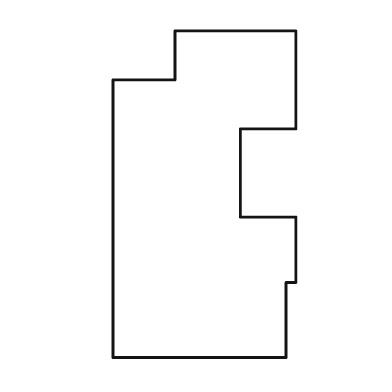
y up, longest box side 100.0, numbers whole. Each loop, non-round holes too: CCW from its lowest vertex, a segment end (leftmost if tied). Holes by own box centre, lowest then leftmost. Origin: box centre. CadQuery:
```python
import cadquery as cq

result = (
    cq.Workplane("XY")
    .moveTo(-28.0, -50.0)
    .lineTo(25.0, -50.0)
    .lineTo(25.0, -27.0)
    .lineTo(28.0, -27.0)
    .lineTo(28.0, -7.0)
    .lineTo(11.0, -7.0)
    .lineTo(11.0, 20.0)
    .lineTo(28.0, 20.0)
    .lineTo(28.0, 50.0)
    .lineTo(-9.0, 50.0)
    .lineTo(-9.0, 35.0)
    .lineTo(-28.0, 35.0)
    .close()
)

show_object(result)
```